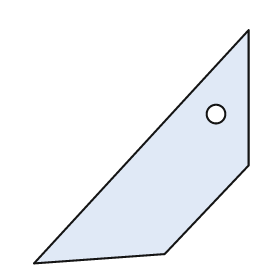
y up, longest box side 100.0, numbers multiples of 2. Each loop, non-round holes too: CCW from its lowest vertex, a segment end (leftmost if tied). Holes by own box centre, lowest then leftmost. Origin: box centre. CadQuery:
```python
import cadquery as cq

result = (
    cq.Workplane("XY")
    .moveTo(-46.0, -50.0)
    .lineTo(10.0, -46.0)
    .lineTo(46.0, -8.0)
    .lineTo(46.0, 50.0)
    .close()
    .moveTo(32.0, 14.0)
    .circle(4.0)
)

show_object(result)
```